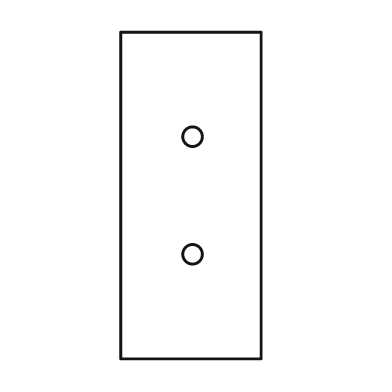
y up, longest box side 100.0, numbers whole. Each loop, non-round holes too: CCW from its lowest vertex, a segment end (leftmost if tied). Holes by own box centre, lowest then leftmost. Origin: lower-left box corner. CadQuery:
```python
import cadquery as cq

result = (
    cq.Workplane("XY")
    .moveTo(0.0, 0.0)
    .lineTo(43.0, 0.0)
    .lineTo(43.0, 100.0)
    .lineTo(0.0, 100.0)
    .close()
    .moveTo(22.0, 32.0)
    .circle(3.0)
    .moveTo(22.0, 68.0)
    .circle(3.0)
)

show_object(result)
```